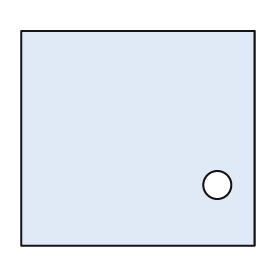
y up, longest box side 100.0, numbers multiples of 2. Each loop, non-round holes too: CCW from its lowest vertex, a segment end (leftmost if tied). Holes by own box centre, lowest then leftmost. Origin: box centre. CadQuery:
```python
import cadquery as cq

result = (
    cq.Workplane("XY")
    .moveTo(-50.0, -46.0)
    .lineTo(50.0, -46.0)
    .lineTo(50.0, 46.0)
    .lineTo(-50.0, 46.0)
    .close()
    .moveTo(34.0, -20.0)
    .circle(6.0)
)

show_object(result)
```